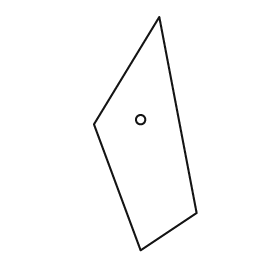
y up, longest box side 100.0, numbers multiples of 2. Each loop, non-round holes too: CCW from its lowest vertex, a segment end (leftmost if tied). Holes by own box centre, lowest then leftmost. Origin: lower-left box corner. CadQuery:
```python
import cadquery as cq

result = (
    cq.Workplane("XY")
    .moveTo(20.0, 0.0)
    .lineTo(44.0, 16.0)
    .lineTo(28.0, 100.0)
    .lineTo(0.0, 54.0)
    .close()
    .moveTo(20.0, 56.0)
    .circle(2.0)
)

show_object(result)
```